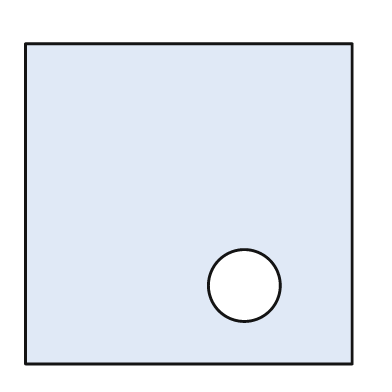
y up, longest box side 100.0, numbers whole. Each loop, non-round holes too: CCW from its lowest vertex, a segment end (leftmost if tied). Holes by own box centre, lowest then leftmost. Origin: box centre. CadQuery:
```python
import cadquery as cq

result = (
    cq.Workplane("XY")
    .moveTo(-50.0, -49.0)
    .lineTo(50.0, -49.0)
    .lineTo(50.0, 49.0)
    .lineTo(-50.0, 49.0)
    .close()
    .moveTo(17.0, -25.0)
    .circle(11.0)
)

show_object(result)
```